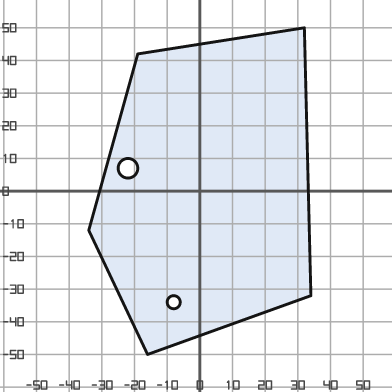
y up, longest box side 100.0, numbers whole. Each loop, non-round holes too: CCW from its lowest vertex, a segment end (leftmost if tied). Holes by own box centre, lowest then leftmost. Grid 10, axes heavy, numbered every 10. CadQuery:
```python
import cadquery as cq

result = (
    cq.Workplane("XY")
    .moveTo(-16.0, -50.0)
    .lineTo(34.0, -32.0)
    .lineTo(32.0, 50.0)
    .lineTo(-19.0, 42.0)
    .lineTo(-34.0, -12.0)
    .close()
    .moveTo(-8.0, -34.0)
    .circle(2.0)
    .moveTo(-22.0, 7.0)
    .circle(3.0)
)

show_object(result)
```